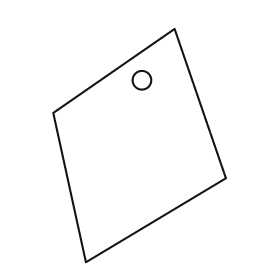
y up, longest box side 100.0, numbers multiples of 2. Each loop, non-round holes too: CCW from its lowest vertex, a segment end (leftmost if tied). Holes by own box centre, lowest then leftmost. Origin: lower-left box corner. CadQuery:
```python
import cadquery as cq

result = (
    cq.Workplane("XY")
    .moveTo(14.0, 0.0)
    .lineTo(74.0, 36.0)
    .lineTo(52.0, 100.0)
    .lineTo(0.0, 64.0)
    .close()
    .moveTo(38.0, 78.0)
    .circle(4.0)
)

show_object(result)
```